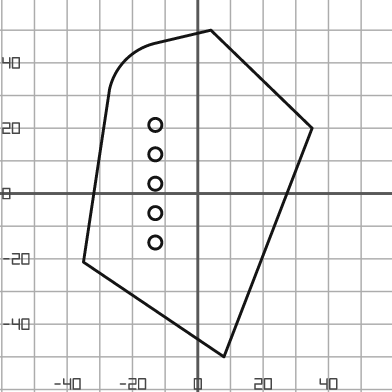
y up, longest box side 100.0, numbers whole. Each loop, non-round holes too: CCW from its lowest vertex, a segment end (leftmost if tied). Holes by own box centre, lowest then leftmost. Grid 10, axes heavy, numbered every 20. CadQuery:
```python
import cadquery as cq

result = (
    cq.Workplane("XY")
    .moveTo(8.0, -50.0)
    .lineTo(35.0, 20.0)
    .lineTo(4.0, 50.0)
    .lineTo(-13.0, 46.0)
    .threePointArc((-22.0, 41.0), (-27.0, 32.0))
    .lineTo(-35.0, -21.0)
    .close()
    .moveTo(-13.0, -15.0)
    .circle(2.0)
    .moveTo(-13.0, -6.0)
    .circle(2.0)
    .moveTo(-13.0, 3.0)
    .circle(2.0)
    .moveTo(-13.0, 12.0)
    .circle(2.0)
    .moveTo(-13.0, 21.0)
    .circle(2.0)
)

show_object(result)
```